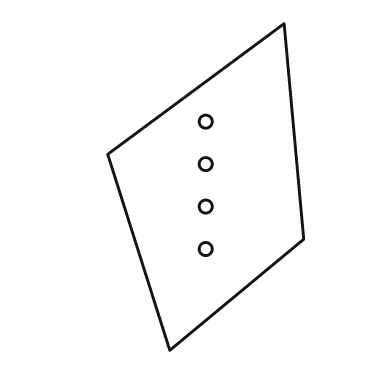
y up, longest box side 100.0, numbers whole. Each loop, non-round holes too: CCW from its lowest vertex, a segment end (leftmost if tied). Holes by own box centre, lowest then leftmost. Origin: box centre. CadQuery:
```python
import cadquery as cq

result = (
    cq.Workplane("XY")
    .moveTo(-11.0, -50.0)
    .lineTo(30.0, -16.0)
    .lineTo(24.0, 50.0)
    .lineTo(-30.0, 10.0)
    .close()
    .moveTo(0.0, -19.0)
    .circle(2.0)
    .moveTo(0.0, -6.0)
    .circle(2.0)
    .moveTo(0.0, 7.0)
    .circle(2.0)
    .moveTo(0.0, 20.0)
    .circle(2.0)
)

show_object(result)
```